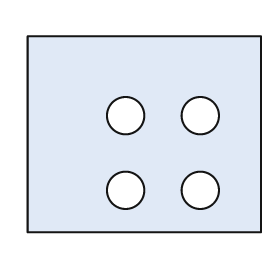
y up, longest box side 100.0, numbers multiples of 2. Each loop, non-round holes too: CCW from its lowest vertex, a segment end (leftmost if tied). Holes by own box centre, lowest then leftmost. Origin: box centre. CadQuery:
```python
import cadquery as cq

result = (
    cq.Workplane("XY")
    .moveTo(-50.0, -42.0)
    .lineTo(50.0, -42.0)
    .lineTo(50.0, 42.0)
    .lineTo(-50.0, 42.0)
    .close()
    .moveTo(-8.0, -24.0)
    .circle(8.0)
    .moveTo(24.0, -24.0)
    .circle(8.0)
    .moveTo(-8.0, 8.0)
    .circle(8.0)
    .moveTo(24.0, 8.0)
    .circle(8.0)
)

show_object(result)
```